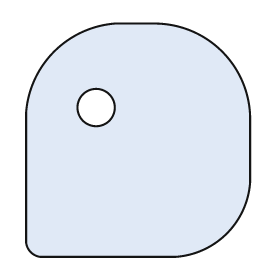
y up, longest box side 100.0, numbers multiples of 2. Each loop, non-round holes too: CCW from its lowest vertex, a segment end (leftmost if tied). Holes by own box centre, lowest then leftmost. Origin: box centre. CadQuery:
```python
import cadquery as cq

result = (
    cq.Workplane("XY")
    .moveTo(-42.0, -50.0)
    .lineTo(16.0, -50.0)
    .threePointArc((38.0, -40.0), (48.0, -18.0))
    .lineTo(48.0, 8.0)
    .threePointArc((36.0, 38.0), (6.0, 50.0))
    .lineTo(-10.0, 50.0)
    .threePointArc((-36.0, 38.0), (-48.0, 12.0))
    .lineTo(-48.0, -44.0)
    .threePointArc((-46.0, -48.0), (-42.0, -50.0))
    .close()
    .moveTo(-18.0, 14.0)
    .circle(8.0)
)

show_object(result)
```